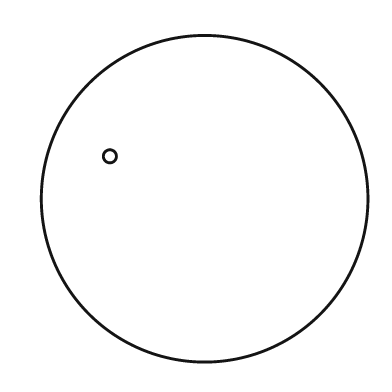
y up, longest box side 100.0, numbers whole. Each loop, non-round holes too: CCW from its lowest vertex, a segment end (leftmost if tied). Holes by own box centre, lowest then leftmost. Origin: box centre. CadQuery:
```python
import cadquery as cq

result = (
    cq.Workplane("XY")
    .moveTo(0.0, 0.0)
    .circle(50.0)
    .moveTo(-29.0, 13.0)
    .circle(2.0)
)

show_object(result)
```